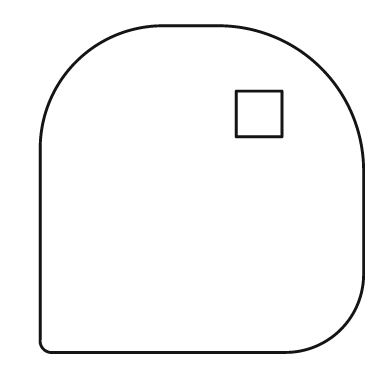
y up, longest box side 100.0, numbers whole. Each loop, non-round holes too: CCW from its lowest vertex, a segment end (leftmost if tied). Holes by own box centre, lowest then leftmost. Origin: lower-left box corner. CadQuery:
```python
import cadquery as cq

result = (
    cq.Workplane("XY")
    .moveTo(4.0, 0.0)
    .lineTo(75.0, 0.0)
    .threePointArc((92.0, 7.0), (99.0, 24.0))
    .lineTo(99.0, 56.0)
    .threePointArc((86.0, 87.0), (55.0, 100.0))
    .lineTo(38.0, 100.0)
    .threePointArc((11.0, 89.0), (0.0, 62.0))
    .lineTo(0.0, 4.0)
    .threePointArc((1.0, 1.0), (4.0, 0.0))
    .close()
    .moveTo(60.0, 66.0)
    .lineTo(74.0, 66.0)
    .lineTo(74.0, 80.0)
    .lineTo(60.0, 80.0)
    .close()
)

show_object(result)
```